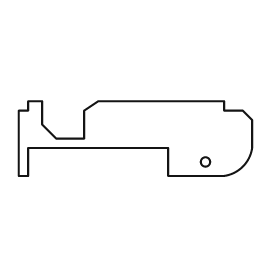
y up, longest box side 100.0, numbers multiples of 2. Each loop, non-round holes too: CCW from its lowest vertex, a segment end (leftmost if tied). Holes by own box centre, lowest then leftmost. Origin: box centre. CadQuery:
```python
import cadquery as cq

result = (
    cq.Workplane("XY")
    .moveTo(-50.0, -16.0)
    .lineTo(-46.0, -16.0)
    .lineTo(-46.0, -4.0)
    .lineTo(14.0, -4.0)
    .lineTo(14.0, -16.0)
    .lineTo(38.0, -16.0)
    .threePointArc((46.0, -12.0), (50.0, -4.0))
    .lineTo(50.0, 8.0)
    .lineTo(46.0, 12.0)
    .lineTo(38.0, 12.0)
    .lineTo(38.0, 16.0)
    .lineTo(-16.0, 16.0)
    .lineTo(-22.0, 12.0)
    .lineTo(-22.0, 0.0)
    .lineTo(-34.0, 0.0)
    .lineTo(-40.0, 6.0)
    .lineTo(-40.0, 16.0)
    .lineTo(-46.0, 16.0)
    .lineTo(-46.0, 12.0)
    .lineTo(-50.0, 12.0)
    .close()
    .moveTo(30.0, -10.0)
    .circle(2.0)
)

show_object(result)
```